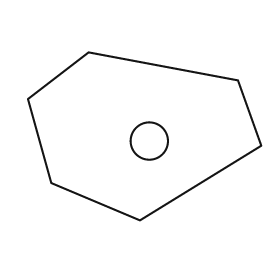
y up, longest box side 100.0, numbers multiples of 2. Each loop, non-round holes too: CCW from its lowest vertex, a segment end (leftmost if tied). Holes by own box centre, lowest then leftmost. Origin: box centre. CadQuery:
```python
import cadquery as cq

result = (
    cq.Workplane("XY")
    .moveTo(-2.0, -36.0)
    .lineTo(50.0, -4.0)
    .lineTo(40.0, 24.0)
    .lineTo(-24.0, 36.0)
    .lineTo(-50.0, 16.0)
    .lineTo(-40.0, -20.0)
    .close()
    .moveTo(2.0, -2.0)
    .circle(8.0)
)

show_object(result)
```